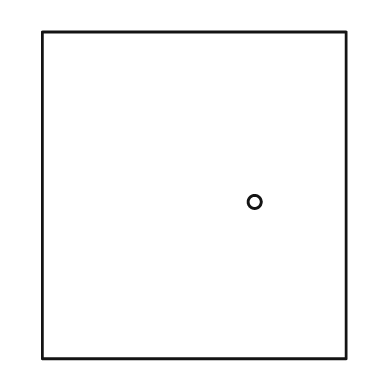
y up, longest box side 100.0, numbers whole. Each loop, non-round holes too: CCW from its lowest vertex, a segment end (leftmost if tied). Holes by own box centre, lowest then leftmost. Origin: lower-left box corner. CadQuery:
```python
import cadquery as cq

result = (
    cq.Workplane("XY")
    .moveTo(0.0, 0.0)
    .lineTo(93.0, 0.0)
    .lineTo(93.0, 100.0)
    .lineTo(0.0, 100.0)
    .close()
    .moveTo(65.0, 48.0)
    .circle(2.0)
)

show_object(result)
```